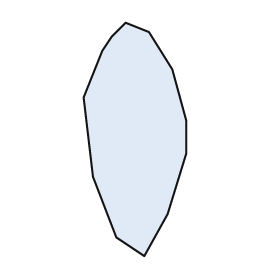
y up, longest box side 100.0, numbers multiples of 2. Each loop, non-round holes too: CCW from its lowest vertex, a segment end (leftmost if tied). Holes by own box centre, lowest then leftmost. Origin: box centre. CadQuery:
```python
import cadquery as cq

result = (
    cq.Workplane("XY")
    .moveTo(4.0, -50.0)
    .lineTo(14.0, -32.0)
    .lineTo(22.0, -6.0)
    .lineTo(22.0, 8.0)
    .lineTo(16.0, 30.0)
    .lineTo(6.0, 46.0)
    .lineTo(-4.0, 50.0)
    .lineTo(-10.0, 44.0)
    .lineTo(-14.0, 38.0)
    .lineTo(-22.0, 18.0)
    .lineTo(-18.0, -16.0)
    .lineTo(-8.0, -42.0)
    .close()
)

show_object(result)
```